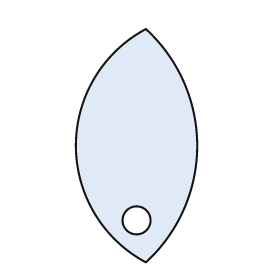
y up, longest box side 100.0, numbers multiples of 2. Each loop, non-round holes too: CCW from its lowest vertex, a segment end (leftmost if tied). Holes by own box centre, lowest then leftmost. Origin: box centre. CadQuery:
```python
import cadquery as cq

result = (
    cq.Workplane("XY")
    .moveTo(4.0, -50.0)
    .threePointArc((26.0, 0.0), (4.0, 50.0))
    .threePointArc((-26.0, 0.0), (4.0, -50.0))
    .close()
    .moveTo(0.0, -32.0)
    .circle(6.0)
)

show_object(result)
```